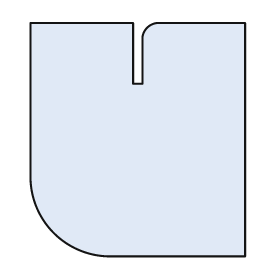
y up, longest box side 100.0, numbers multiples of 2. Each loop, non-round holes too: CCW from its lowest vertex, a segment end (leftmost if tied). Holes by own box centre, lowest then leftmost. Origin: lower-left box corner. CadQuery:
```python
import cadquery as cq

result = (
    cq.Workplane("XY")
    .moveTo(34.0, 0.0)
    .lineTo(92.0, 0.0)
    .lineTo(92.0, 100.0)
    .lineTo(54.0, 100.0)
    .threePointArc((50.0, 98.0), (48.0, 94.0))
    .lineTo(48.0, 74.0)
    .lineTo(44.0, 74.0)
    .lineTo(44.0, 100.0)
    .lineTo(0.0, 100.0)
    .lineTo(0.0, 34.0)
    .threePointArc((10.0, 10.0), (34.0, 0.0))
    .close()
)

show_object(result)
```